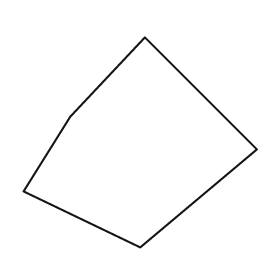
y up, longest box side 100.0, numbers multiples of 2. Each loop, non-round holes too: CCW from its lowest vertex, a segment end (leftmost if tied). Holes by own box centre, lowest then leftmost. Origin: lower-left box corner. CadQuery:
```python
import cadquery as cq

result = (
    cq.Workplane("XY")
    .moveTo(50.0, 0.0)
    .lineTo(100.0, 42.0)
    .lineTo(52.0, 90.0)
    .lineTo(20.0, 56.0)
    .lineTo(0.0, 24.0)
    .close()
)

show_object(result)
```